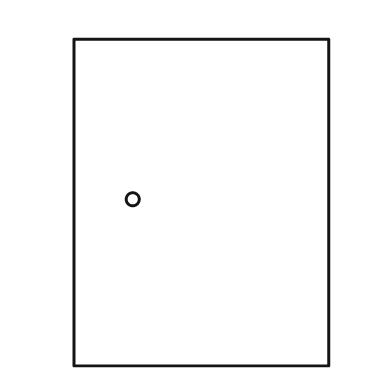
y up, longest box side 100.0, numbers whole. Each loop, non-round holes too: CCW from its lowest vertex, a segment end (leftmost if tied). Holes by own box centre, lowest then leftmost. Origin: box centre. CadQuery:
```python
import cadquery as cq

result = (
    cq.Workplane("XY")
    .moveTo(-39.0, -50.0)
    .lineTo(39.0, -50.0)
    .lineTo(39.0, 50.0)
    .lineTo(-39.0, 50.0)
    .close()
    .moveTo(-21.0, 1.0)
    .circle(2.0)
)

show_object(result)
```